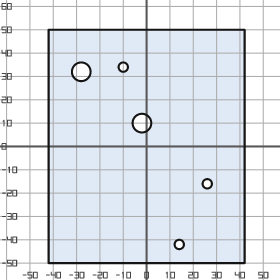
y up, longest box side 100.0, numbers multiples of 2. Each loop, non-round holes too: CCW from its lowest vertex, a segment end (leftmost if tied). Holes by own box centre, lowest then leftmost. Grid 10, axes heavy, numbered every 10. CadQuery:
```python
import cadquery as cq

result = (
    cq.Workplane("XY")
    .moveTo(-42.0, -50.0)
    .lineTo(42.0, -50.0)
    .lineTo(42.0, 50.0)
    .lineTo(-42.0, 50.0)
    .close()
    .moveTo(14.0, -42.0)
    .circle(2.0)
    .moveTo(26.0, -16.0)
    .circle(2.0)
    .moveTo(-2.0, 10.0)
    .circle(4.0)
    .moveTo(-28.0, 32.0)
    .circle(4.0)
    .moveTo(-10.0, 34.0)
    .circle(2.0)
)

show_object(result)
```